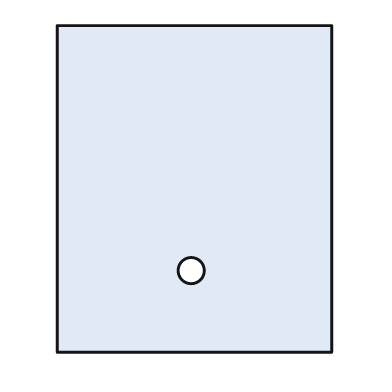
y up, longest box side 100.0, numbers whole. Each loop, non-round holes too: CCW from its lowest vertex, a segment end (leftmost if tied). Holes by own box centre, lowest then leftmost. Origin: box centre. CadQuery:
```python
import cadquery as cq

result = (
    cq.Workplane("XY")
    .moveTo(-42.0, -50.0)
    .lineTo(42.0, -50.0)
    .lineTo(42.0, 50.0)
    .lineTo(-42.0, 50.0)
    .close()
    .moveTo(-1.0, -25.0)
    .circle(4.0)
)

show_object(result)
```